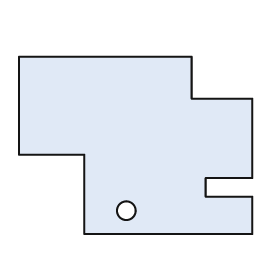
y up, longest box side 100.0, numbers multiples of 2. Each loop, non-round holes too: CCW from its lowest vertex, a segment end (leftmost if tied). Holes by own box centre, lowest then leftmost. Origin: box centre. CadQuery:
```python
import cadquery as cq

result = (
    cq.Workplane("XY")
    .moveTo(-22.0, -38.0)
    .lineTo(50.0, -38.0)
    .lineTo(50.0, -22.0)
    .lineTo(30.0, -22.0)
    .lineTo(30.0, -14.0)
    .lineTo(50.0, -14.0)
    .lineTo(50.0, 20.0)
    .lineTo(24.0, 20.0)
    .lineTo(24.0, 38.0)
    .lineTo(-50.0, 38.0)
    .lineTo(-50.0, -4.0)
    .lineTo(-22.0, -4.0)
    .close()
    .moveTo(-4.0, -28.0)
    .circle(4.0)
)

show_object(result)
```